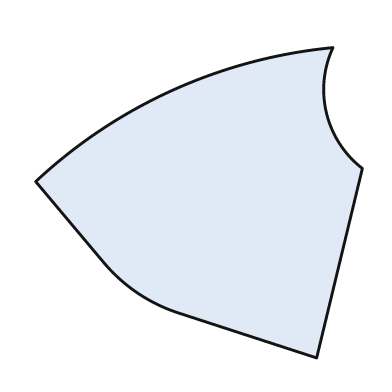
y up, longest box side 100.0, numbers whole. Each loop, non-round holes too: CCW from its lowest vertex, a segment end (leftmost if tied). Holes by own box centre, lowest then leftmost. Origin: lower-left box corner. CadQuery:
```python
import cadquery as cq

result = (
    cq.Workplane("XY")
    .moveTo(86.0, 0.0)
    .lineTo(100.0, 58.0)
    .threePointArc((89.0, 75.0), (91.0, 95.0))
    .threePointArc((42.0, 82.0), (0.0, 54.0))
    .lineTo(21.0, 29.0)
    .threePointArc((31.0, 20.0), (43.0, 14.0))
    .close()
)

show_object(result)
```